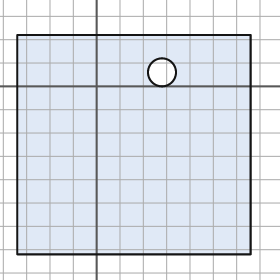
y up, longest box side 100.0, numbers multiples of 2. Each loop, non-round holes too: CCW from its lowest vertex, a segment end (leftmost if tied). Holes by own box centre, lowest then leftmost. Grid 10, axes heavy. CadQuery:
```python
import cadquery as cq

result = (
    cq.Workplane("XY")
    .moveTo(-34.0, -72.0)
    .lineTo(66.0, -72.0)
    .lineTo(66.0, 22.0)
    .lineTo(-34.0, 22.0)
    .close()
    .moveTo(28.0, 6.0)
    .circle(6.0)
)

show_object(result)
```